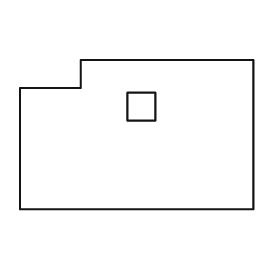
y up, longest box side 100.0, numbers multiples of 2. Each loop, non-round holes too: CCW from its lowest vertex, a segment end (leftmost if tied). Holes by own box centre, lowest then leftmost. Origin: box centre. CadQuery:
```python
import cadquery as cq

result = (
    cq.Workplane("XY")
    .moveTo(-50.0, -32.0)
    .lineTo(50.0, -32.0)
    .lineTo(50.0, 32.0)
    .lineTo(-24.0, 32.0)
    .lineTo(-24.0, 20.0)
    .lineTo(-50.0, 20.0)
    .close()
    .moveTo(-4.0, 6.0)
    .lineTo(8.0, 6.0)
    .lineTo(8.0, 18.0)
    .lineTo(-4.0, 18.0)
    .close()
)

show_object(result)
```